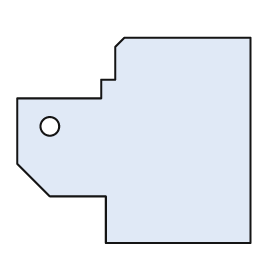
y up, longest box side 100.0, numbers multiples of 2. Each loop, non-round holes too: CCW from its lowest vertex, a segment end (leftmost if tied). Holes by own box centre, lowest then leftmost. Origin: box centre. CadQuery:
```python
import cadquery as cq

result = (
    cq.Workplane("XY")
    .moveTo(-12.0, -44.0)
    .lineTo(50.0, -44.0)
    .lineTo(50.0, 44.0)
    .lineTo(-4.0, 44.0)
    .lineTo(-8.0, 40.0)
    .lineTo(-8.0, 26.0)
    .lineTo(-14.0, 26.0)
    .lineTo(-14.0, 18.0)
    .lineTo(-50.0, 18.0)
    .lineTo(-50.0, -10.0)
    .lineTo(-36.0, -24.0)
    .lineTo(-12.0, -24.0)
    .close()
    .moveTo(-36.0, 6.0)
    .circle(4.0)
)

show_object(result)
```